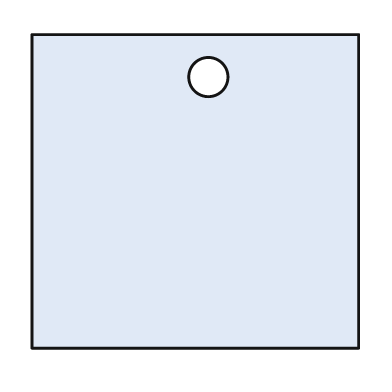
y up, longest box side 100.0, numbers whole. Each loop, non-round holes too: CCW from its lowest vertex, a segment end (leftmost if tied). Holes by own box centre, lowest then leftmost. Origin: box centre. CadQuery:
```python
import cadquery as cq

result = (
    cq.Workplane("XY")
    .moveTo(-50.0, -48.0)
    .lineTo(50.0, -48.0)
    .lineTo(50.0, 48.0)
    .lineTo(-50.0, 48.0)
    .close()
    .moveTo(4.0, 35.0)
    .circle(6.0)
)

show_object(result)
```